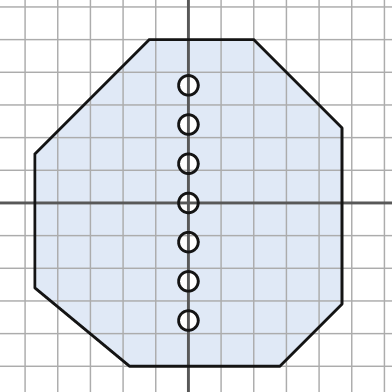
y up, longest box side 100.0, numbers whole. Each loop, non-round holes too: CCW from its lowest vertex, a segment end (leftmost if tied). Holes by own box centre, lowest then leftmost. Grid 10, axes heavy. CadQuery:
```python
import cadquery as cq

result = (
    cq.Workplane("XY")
    .moveTo(-18.0, -50.0)
    .lineTo(28.0, -50.0)
    .lineTo(47.0, -31.0)
    .lineTo(47.0, 23.0)
    .lineTo(20.0, 50.0)
    .lineTo(-12.0, 50.0)
    .lineTo(-47.0, 15.0)
    .lineTo(-47.0, -26.0)
    .close()
    .moveTo(0.0, -36.0)
    .circle(3.0)
    .moveTo(0.0, -24.0)
    .circle(3.0)
    .moveTo(0.0, -12.0)
    .circle(3.0)
    .moveTo(0.0, 0.0)
    .circle(3.0)
    .moveTo(0.0, 12.0)
    .circle(3.0)
    .moveTo(0.0, 24.0)
    .circle(3.0)
    .moveTo(0.0, 36.0)
    .circle(3.0)
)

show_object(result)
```